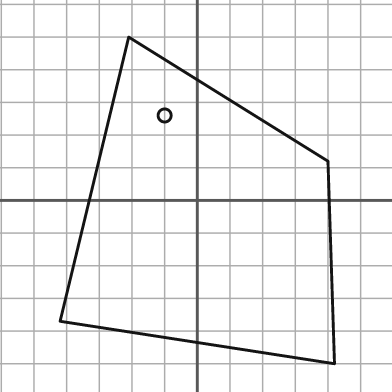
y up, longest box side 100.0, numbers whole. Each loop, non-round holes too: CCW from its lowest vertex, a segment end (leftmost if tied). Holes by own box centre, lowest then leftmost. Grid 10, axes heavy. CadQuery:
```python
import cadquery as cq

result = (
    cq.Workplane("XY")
    .moveTo(42.0, -50.0)
    .lineTo(40.0, 12.0)
    .lineTo(-21.0, 50.0)
    .lineTo(-42.0, -37.0)
    .close()
    .moveTo(-10.0, 26.0)
    .circle(2.0)
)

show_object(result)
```